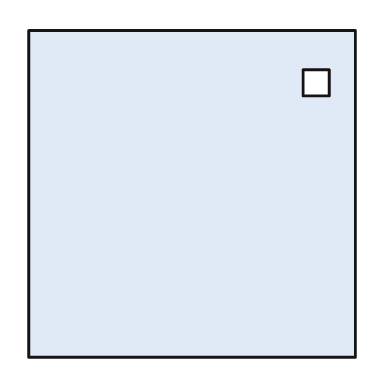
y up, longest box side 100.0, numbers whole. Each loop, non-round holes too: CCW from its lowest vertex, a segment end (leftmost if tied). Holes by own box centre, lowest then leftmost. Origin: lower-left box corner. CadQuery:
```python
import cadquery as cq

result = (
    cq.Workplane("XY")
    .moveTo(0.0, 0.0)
    .lineTo(100.0, 0.0)
    .lineTo(100.0, 100.0)
    .lineTo(0.0, 100.0)
    .close()
    .moveTo(84.0, 80.0)
    .lineTo(92.0, 80.0)
    .lineTo(92.0, 88.0)
    .lineTo(84.0, 88.0)
    .close()
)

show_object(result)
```